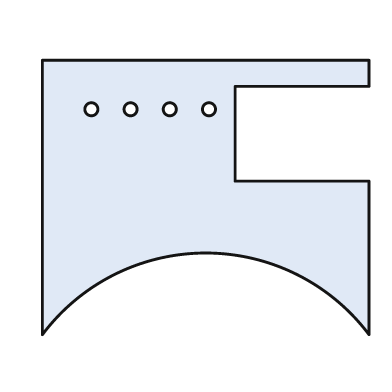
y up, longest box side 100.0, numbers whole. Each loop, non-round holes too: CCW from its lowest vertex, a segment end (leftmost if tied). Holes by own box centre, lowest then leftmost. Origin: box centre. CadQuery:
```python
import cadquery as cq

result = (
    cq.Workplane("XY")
    .moveTo(-50.0, -42.0)
    .threePointArc((0.0, -17.0), (50.0, -42.0))
    .lineTo(50.0, 5.0)
    .lineTo(9.0, 5.0)
    .lineTo(9.0, 34.0)
    .lineTo(50.0, 34.0)
    .lineTo(50.0, 42.0)
    .lineTo(-50.0, 42.0)
    .close()
    .moveTo(-35.0, 27.0)
    .circle(2.0)
    .moveTo(-23.0, 27.0)
    .circle(2.0)
    .moveTo(-11.0, 27.0)
    .circle(2.0)
    .moveTo(1.0, 27.0)
    .circle(2.0)
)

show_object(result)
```